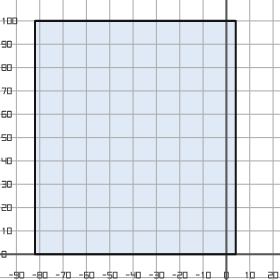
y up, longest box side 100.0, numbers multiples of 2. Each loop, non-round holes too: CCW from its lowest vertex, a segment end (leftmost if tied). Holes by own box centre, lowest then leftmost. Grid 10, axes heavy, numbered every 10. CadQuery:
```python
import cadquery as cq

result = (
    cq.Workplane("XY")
    .moveTo(-82.0, 0.0)
    .lineTo(4.0, 0.0)
    .lineTo(4.0, 100.0)
    .lineTo(-82.0, 100.0)
    .close()
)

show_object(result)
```